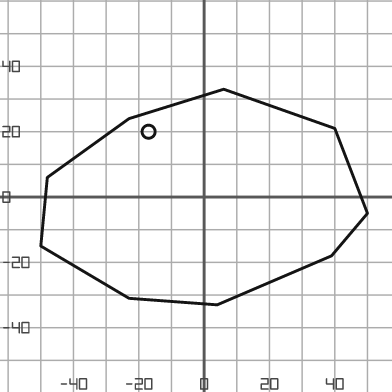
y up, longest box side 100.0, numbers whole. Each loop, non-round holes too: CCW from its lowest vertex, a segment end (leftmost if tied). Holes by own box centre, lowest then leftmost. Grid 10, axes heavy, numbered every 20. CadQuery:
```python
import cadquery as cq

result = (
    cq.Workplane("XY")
    .moveTo(4.0, -33.0)
    .lineTo(39.0, -18.0)
    .lineTo(50.0, -5.0)
    .lineTo(40.0, 21.0)
    .lineTo(6.0, 33.0)
    .lineTo(-23.0, 24.0)
    .lineTo(-48.0, 6.0)
    .lineTo(-50.0, -15.0)
    .lineTo(-23.0, -31.0)
    .close()
    .moveTo(-17.0, 20.0)
    .circle(2.0)
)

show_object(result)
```